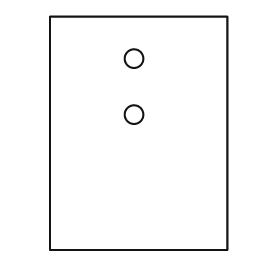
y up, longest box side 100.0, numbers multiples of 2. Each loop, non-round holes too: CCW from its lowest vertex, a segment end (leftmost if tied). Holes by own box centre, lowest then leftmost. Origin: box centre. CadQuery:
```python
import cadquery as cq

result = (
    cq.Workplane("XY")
    .moveTo(-38.0, -50.0)
    .lineTo(38.0, -50.0)
    .lineTo(38.0, 50.0)
    .lineTo(-38.0, 50.0)
    .close()
    .moveTo(-2.0, 8.0)
    .circle(4.0)
    .moveTo(-2.0, 32.0)
    .circle(4.0)
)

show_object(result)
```